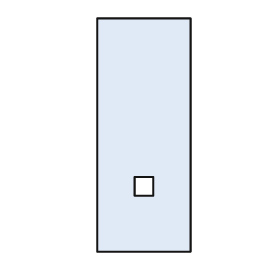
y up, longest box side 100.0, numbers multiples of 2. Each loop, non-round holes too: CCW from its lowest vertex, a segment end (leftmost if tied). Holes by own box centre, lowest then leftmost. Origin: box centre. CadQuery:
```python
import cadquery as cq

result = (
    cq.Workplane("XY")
    .moveTo(-20.0, -50.0)
    .lineTo(20.0, -50.0)
    .lineTo(20.0, 50.0)
    .lineTo(-20.0, 50.0)
    .close()
    .moveTo(-4.0, -26.0)
    .lineTo(4.0, -26.0)
    .lineTo(4.0, -18.0)
    .lineTo(-4.0, -18.0)
    .close()
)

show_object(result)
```